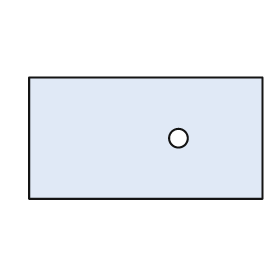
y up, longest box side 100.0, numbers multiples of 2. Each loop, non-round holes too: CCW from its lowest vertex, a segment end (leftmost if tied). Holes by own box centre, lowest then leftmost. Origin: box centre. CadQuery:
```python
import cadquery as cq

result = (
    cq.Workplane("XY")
    .moveTo(-50.0, -26.0)
    .lineTo(50.0, -26.0)
    .lineTo(50.0, 26.0)
    .lineTo(-50.0, 26.0)
    .close()
    .moveTo(14.0, 0.0)
    .circle(4.0)
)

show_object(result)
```